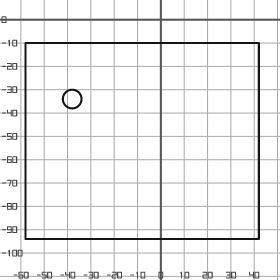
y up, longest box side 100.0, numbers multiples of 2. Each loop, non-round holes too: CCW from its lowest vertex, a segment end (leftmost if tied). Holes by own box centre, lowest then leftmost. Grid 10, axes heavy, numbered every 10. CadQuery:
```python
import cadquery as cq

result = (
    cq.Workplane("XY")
    .moveTo(-58.0, -94.0)
    .lineTo(42.0, -94.0)
    .lineTo(42.0, -10.0)
    .lineTo(-58.0, -10.0)
    .close()
    .moveTo(-38.0, -34.0)
    .circle(4.0)
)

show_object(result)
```